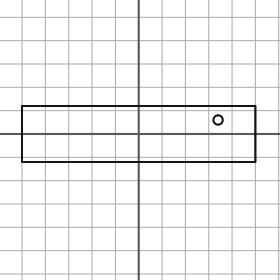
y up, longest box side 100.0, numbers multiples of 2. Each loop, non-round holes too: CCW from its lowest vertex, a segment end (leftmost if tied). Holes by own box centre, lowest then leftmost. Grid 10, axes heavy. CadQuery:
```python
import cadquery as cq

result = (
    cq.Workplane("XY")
    .moveTo(-50.0, -12.0)
    .lineTo(50.0, -12.0)
    .lineTo(50.0, 12.0)
    .lineTo(-50.0, 12.0)
    .close()
    .moveTo(34.0, 6.0)
    .circle(2.0)
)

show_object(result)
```